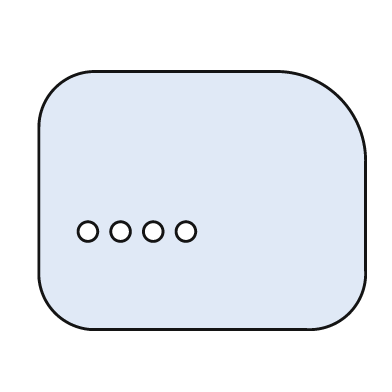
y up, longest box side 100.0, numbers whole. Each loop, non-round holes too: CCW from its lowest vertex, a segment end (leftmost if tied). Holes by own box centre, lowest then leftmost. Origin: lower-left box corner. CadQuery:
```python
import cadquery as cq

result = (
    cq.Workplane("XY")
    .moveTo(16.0, 0.0)
    .lineTo(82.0, 0.0)
    .threePointArc((95.0, 5.0), (100.0, 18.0))
    .lineTo(100.0, 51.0)
    .threePointArc((92.0, 71.0), (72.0, 79.0))
    .lineTo(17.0, 79.0)
    .threePointArc((5.0, 74.0), (0.0, 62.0))
    .lineTo(0.0, 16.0)
    .threePointArc((5.0, 5.0), (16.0, 0.0))
    .close()
    .moveTo(15.0, 30.0)
    .circle(3.0)
    .moveTo(25.0, 30.0)
    .circle(3.0)
    .moveTo(35.0, 30.0)
    .circle(3.0)
    .moveTo(45.0, 30.0)
    .circle(3.0)
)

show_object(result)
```